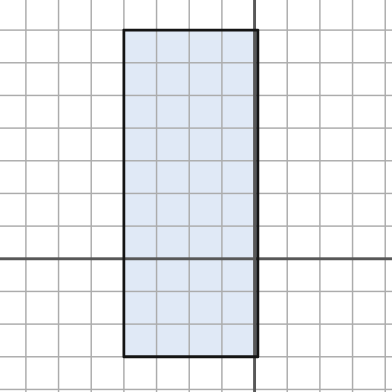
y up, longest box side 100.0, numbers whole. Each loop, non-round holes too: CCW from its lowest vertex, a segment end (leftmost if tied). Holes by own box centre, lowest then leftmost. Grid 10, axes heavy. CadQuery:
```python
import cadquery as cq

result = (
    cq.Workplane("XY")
    .moveTo(-40.0, -30.0)
    .lineTo(1.0, -30.0)
    .lineTo(1.0, 70.0)
    .lineTo(-40.0, 70.0)
    .close()
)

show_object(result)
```